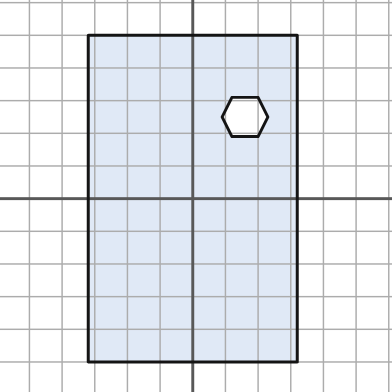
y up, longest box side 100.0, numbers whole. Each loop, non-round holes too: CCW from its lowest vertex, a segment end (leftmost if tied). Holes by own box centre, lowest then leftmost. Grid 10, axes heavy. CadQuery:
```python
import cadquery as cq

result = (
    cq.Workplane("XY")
    .moveTo(-32.0, -50.0)
    .lineTo(32.0, -50.0)
    .lineTo(32.0, 50.0)
    .lineTo(-32.0, 50.0)
    .close()
    .moveTo(12.0, 19.0)
    .lineTo(20.0, 19.0)
    .lineTo(23.0, 25.0)
    .lineTo(20.0, 31.0)
    .lineTo(12.0, 31.0)
    .lineTo(9.0, 25.0)
    .close()
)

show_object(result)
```